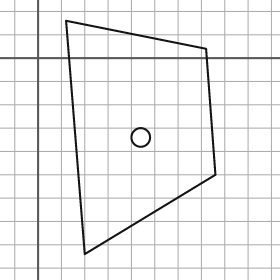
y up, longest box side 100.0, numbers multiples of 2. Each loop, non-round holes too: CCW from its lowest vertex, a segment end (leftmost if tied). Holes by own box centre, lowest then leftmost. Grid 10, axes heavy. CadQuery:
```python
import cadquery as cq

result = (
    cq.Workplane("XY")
    .moveTo(20.0, -84.0)
    .lineTo(76.0, -50.0)
    .lineTo(72.0, 4.0)
    .lineTo(12.0, 16.0)
    .close()
    .moveTo(44.0, -34.0)
    .circle(4.0)
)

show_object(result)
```